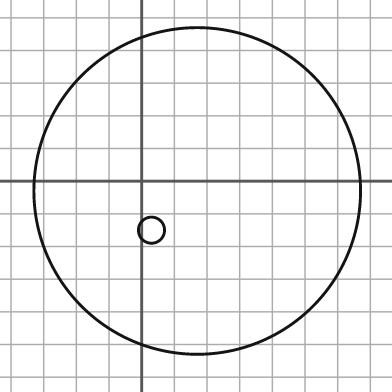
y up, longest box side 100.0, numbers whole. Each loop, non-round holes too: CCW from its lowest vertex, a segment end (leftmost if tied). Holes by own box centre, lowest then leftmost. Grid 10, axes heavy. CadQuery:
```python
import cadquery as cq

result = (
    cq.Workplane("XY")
    .moveTo(17.0, -3.0)
    .circle(50.0)
    .moveTo(3.0, -15.0)
    .circle(4.0)
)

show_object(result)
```